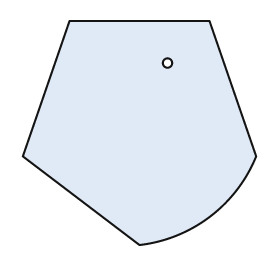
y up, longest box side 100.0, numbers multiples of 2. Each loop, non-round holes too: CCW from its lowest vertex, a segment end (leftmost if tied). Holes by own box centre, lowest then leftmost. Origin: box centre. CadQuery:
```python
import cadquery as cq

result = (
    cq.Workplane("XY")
    .moveTo(0.0, -48.0)
    .threePointArc((30.0, -36.0), (50.0, -10.0))
    .lineTo(30.0, 48.0)
    .lineTo(-30.0, 48.0)
    .lineTo(-50.0, -10.0)
    .close()
    .moveTo(12.0, 30.0)
    .circle(2.0)
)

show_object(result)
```